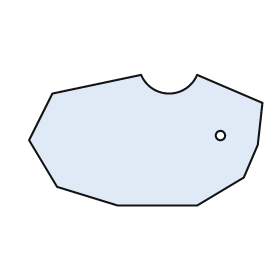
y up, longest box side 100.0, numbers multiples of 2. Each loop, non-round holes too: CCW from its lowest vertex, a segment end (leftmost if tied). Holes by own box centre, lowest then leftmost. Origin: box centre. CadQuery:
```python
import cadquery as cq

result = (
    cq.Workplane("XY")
    .moveTo(-12.0, -28.0)
    .lineTo(22.0, -28.0)
    .lineTo(42.0, -16.0)
    .lineTo(48.0, -2.0)
    .lineTo(50.0, 16.0)
    .lineTo(22.0, 28.0)
    .threePointArc((10.0, 20.0), (-2.0, 28.0))
    .lineTo(-40.0, 20.0)
    .lineTo(-50.0, 0.0)
    .lineTo(-38.0, -20.0)
    .close()
    .moveTo(32.0, 2.0)
    .circle(2.0)
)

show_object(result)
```